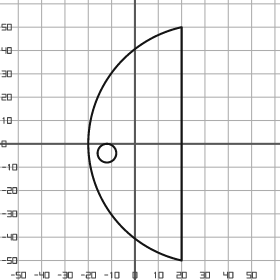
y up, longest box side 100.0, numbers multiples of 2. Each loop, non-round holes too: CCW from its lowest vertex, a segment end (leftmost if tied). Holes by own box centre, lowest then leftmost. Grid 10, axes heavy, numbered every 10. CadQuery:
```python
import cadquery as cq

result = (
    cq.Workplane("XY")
    .moveTo(20.0, -50.0)
    .lineTo(20.0, 50.0)
    .threePointArc((-20.0, 0.0), (20.0, -50.0))
    .close()
    .moveTo(-12.0, -4.0)
    .circle(4.0)
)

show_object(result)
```